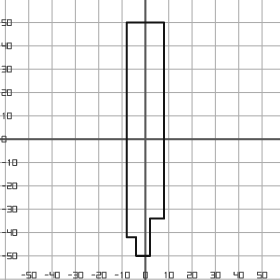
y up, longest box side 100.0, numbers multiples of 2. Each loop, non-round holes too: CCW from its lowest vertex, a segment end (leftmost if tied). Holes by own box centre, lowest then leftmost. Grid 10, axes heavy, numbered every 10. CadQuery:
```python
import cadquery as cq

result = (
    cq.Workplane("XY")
    .moveTo(-4.0, -50.0)
    .lineTo(2.0, -50.0)
    .lineTo(2.0, -34.0)
    .lineTo(8.0, -34.0)
    .lineTo(8.0, 50.0)
    .lineTo(-8.0, 50.0)
    .lineTo(-8.0, -42.0)
    .lineTo(-4.0, -42.0)
    .close()
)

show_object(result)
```